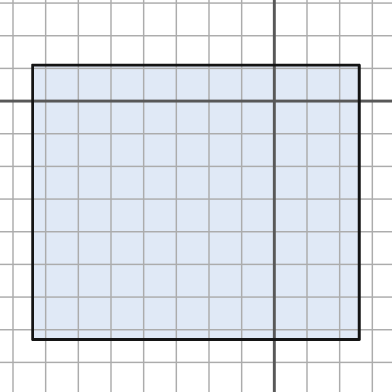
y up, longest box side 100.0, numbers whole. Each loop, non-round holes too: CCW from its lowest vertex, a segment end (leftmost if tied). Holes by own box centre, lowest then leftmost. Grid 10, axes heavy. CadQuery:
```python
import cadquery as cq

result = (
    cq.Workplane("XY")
    .moveTo(-74.0, -73.0)
    .lineTo(26.0, -73.0)
    .lineTo(26.0, 11.0)
    .lineTo(-74.0, 11.0)
    .close()
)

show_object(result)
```